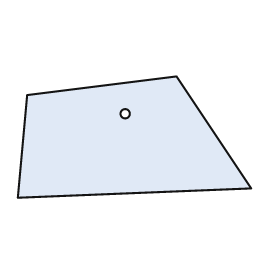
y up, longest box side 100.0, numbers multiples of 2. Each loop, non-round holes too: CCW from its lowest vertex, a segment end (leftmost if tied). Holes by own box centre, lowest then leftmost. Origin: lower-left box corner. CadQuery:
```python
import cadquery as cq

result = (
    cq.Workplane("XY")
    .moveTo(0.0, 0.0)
    .lineTo(100.0, 4.0)
    .lineTo(68.0, 52.0)
    .lineTo(4.0, 44.0)
    .close()
    .moveTo(46.0, 36.0)
    .circle(2.0)
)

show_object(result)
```